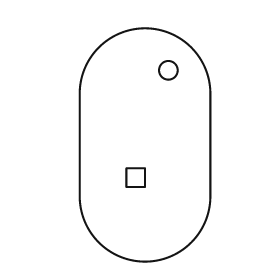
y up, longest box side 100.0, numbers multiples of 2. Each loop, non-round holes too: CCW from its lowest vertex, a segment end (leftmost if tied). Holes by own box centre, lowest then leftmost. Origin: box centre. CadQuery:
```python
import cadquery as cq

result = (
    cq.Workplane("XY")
    .moveTo(-28.0, -22.0)
    .threePointArc((0.0, -50.0), (28.0, -22.0))
    .lineTo(28.0, 22.0)
    .threePointArc((0.0, 50.0), (-28.0, 22.0))
    .close()
    .moveTo(-8.0, -18.0)
    .lineTo(0.0, -18.0)
    .lineTo(0.0, -10.0)
    .lineTo(-8.0, -10.0)
    .close()
    .moveTo(10.0, 32.0)
    .circle(4.0)
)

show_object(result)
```